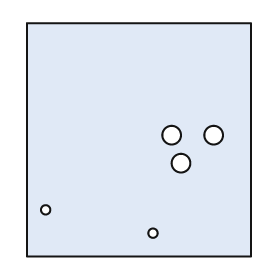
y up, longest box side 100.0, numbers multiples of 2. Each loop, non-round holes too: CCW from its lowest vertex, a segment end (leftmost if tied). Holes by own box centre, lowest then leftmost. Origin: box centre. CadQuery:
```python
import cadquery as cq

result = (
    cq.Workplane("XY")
    .moveTo(-48.0, -50.0)
    .lineTo(48.0, -50.0)
    .lineTo(48.0, 50.0)
    .lineTo(-48.0, 50.0)
    .close()
    .moveTo(6.0, -40.0)
    .circle(2.0)
    .moveTo(-40.0, -30.0)
    .circle(2.0)
    .moveTo(18.0, -10.0)
    .circle(4.0)
    .moveTo(14.0, 2.0)
    .circle(4.0)
    .moveTo(32.0, 2.0)
    .circle(4.0)
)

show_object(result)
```